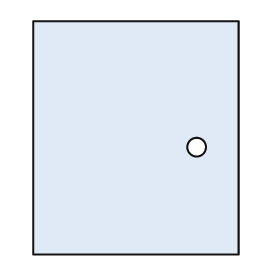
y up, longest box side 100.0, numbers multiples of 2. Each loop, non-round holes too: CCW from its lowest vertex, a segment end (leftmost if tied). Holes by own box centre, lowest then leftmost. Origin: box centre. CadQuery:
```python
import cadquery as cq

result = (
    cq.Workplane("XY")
    .moveTo(-44.0, -50.0)
    .lineTo(44.0, -50.0)
    .lineTo(44.0, 50.0)
    .lineTo(-44.0, 50.0)
    .close()
    .moveTo(26.0, -4.0)
    .circle(4.0)
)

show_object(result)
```